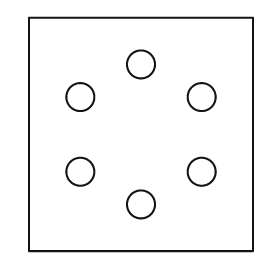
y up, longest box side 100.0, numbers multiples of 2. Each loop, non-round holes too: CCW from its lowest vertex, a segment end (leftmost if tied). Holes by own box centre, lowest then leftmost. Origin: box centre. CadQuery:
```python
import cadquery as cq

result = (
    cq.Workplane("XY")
    .moveTo(-48.0, -50.0)
    .lineTo(48.0, -50.0)
    .lineTo(48.0, 50.0)
    .lineTo(-48.0, 50.0)
    .close()
    .moveTo(0.0, -30.0)
    .circle(6.0)
    .moveTo(-26.0, -16.0)
    .circle(6.0)
    .moveTo(26.0, -16.0)
    .circle(6.0)
    .moveTo(-26.0, 16.0)
    .circle(6.0)
    .moveTo(26.0, 16.0)
    .circle(6.0)
    .moveTo(0.0, 30.0)
    .circle(6.0)
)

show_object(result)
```